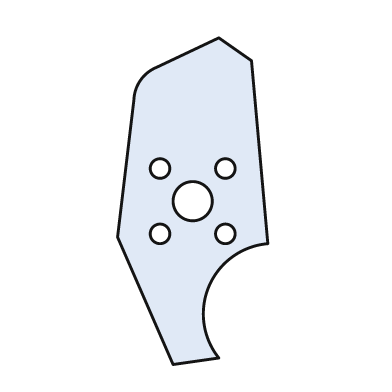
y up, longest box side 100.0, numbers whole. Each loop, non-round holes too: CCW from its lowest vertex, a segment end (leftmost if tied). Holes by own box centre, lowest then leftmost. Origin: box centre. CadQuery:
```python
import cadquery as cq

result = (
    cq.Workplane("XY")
    .moveTo(-6.0, -50.0)
    .lineTo(8.0, -48.0)
    .threePointArc((5.0, -26.0), (23.0, -13.0))
    .lineTo(18.0, 43.0)
    .lineTo(8.0, 50.0)
    .lineTo(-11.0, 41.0)
    .threePointArc((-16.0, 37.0), (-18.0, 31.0))
    .lineTo(-23.0, -11.0)
    .close()
    .moveTo(-10.0, -10.0)
    .circle(3.0)
    .moveTo(10.0, -10.0)
    .circle(3.0)
    .moveTo(0.0, 0.0)
    .circle(6.0)
    .moveTo(-10.0, 10.0)
    .circle(3.0)
    .moveTo(10.0, 10.0)
    .circle(3.0)
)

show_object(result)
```